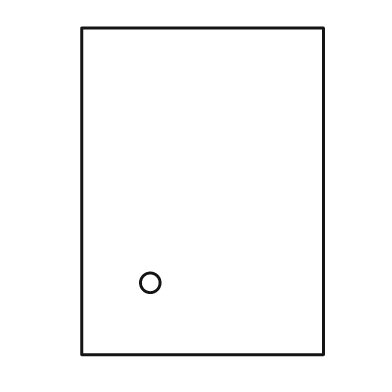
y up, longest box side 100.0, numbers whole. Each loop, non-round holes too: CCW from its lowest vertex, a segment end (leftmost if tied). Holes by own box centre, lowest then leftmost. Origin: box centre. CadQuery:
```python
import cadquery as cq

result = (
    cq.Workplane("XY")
    .moveTo(-37.0, -50.0)
    .lineTo(37.0, -50.0)
    .lineTo(37.0, 50.0)
    .lineTo(-37.0, 50.0)
    .close()
    .moveTo(-16.0, -28.0)
    .circle(3.0)
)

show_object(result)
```